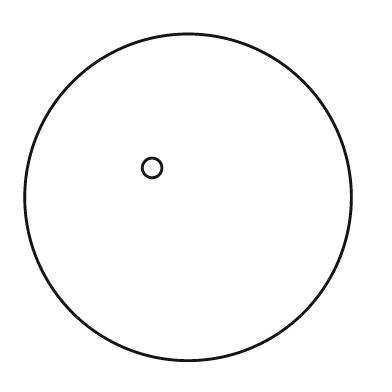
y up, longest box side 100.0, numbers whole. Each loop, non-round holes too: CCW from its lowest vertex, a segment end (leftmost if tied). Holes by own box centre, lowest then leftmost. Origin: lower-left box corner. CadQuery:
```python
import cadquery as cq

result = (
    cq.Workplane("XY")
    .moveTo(50.0, 50.0)
    .circle(50.0)
    .moveTo(39.0, 59.0)
    .circle(3.0)
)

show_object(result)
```